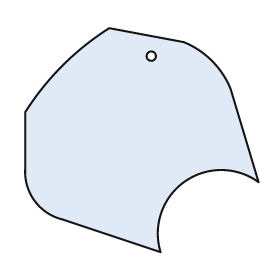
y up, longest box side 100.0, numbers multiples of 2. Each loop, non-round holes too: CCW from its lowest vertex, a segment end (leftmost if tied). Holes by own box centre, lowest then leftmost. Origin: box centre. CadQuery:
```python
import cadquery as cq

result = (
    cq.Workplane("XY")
    .moveTo(8.0, -48.0)
    .threePointArc((18.0, -18.0), (50.0, -18.0))
    .lineTo(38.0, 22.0)
    .threePointArc((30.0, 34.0), (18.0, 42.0))
    .lineTo(-14.0, 48.0)
    .threePointArc((-34.0, 32.0), (-50.0, 12.0))
    .lineTo(-50.0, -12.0)
    .threePointArc((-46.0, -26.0), (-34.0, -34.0))
    .close()
    .moveTo(4.0, 36.0)
    .circle(2.0)
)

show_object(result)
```